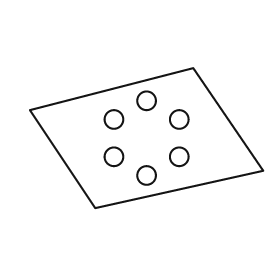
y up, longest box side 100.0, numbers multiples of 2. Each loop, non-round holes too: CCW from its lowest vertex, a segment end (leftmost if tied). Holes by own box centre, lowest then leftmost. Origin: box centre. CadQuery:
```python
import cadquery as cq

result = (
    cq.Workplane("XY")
    .moveTo(-22.0, -30.0)
    .lineTo(50.0, -14.0)
    .lineTo(20.0, 30.0)
    .lineTo(-50.0, 12.0)
    .close()
    .moveTo(0.0, -16.0)
    .circle(4.0)
    .moveTo(-14.0, -8.0)
    .circle(4.0)
    .moveTo(14.0, -8.0)
    .circle(4.0)
    .moveTo(-14.0, 8.0)
    .circle(4.0)
    .moveTo(14.0, 8.0)
    .circle(4.0)
    .moveTo(0.0, 16.0)
    .circle(4.0)
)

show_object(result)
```